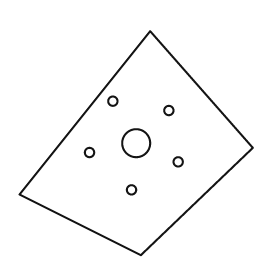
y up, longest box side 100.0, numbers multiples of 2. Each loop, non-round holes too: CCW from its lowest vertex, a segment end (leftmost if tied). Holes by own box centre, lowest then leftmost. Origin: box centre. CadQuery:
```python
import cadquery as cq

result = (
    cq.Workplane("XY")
    .moveTo(2.0, -48.0)
    .lineTo(50.0, -2.0)
    .lineTo(6.0, 48.0)
    .lineTo(-50.0, -22.0)
    .close()
    .moveTo(-2.0, -20.0)
    .circle(2.0)
    .moveTo(18.0, -8.0)
    .circle(2.0)
    .moveTo(-20.0, -4.0)
    .circle(2.0)
    .moveTo(0.0, 0.0)
    .circle(6.0)
    .moveTo(14.0, 14.0)
    .circle(2.0)
    .moveTo(-10.0, 18.0)
    .circle(2.0)
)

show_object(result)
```